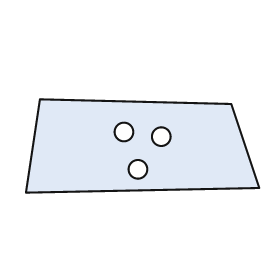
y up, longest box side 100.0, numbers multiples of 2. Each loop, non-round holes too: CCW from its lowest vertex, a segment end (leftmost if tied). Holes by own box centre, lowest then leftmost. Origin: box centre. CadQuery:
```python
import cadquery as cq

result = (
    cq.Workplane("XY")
    .moveTo(-50.0, -20.0)
    .lineTo(50.0, -18.0)
    .lineTo(38.0, 18.0)
    .lineTo(-44.0, 20.0)
    .close()
    .moveTo(-2.0, -10.0)
    .circle(4.0)
    .moveTo(8.0, 4.0)
    .circle(4.0)
    .moveTo(-8.0, 6.0)
    .circle(4.0)
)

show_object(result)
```